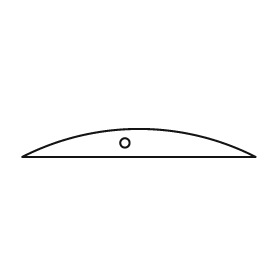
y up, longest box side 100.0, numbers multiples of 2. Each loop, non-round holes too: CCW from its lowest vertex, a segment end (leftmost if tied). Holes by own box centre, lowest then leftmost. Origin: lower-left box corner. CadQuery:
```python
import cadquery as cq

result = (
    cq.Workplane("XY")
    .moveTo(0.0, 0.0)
    .lineTo(100.0, 0.0)
    .threePointArc((50.0, 12.0), (0.0, 0.0))
    .close()
    .moveTo(44.0, 6.0)
    .circle(2.0)
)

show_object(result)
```